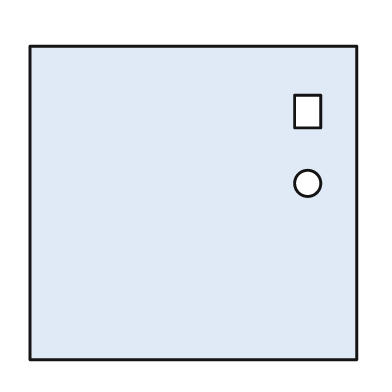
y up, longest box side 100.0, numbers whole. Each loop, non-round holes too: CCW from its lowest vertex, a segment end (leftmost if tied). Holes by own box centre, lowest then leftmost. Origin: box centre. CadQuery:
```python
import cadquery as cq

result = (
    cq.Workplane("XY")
    .moveTo(-50.0, -48.0)
    .lineTo(50.0, -48.0)
    .lineTo(50.0, 48.0)
    .lineTo(-50.0, 48.0)
    .close()
    .moveTo(35.0, 6.0)
    .circle(4.0)
    .moveTo(31.0, 23.0)
    .lineTo(39.0, 23.0)
    .lineTo(39.0, 33.0)
    .lineTo(31.0, 33.0)
    .close()
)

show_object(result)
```